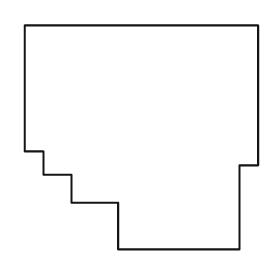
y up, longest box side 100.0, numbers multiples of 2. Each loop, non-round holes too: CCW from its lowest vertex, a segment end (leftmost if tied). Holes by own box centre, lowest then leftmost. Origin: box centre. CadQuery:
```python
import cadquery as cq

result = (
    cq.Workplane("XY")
    .moveTo(-10.0, -48.0)
    .lineTo(42.0, -48.0)
    .lineTo(42.0, -12.0)
    .lineTo(50.0, -12.0)
    .lineTo(50.0, 48.0)
    .lineTo(-50.0, 48.0)
    .lineTo(-50.0, -6.0)
    .lineTo(-42.0, -6.0)
    .lineTo(-42.0, -16.0)
    .lineTo(-30.0, -16.0)
    .lineTo(-30.0, -28.0)
    .lineTo(-10.0, -28.0)
    .close()
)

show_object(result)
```